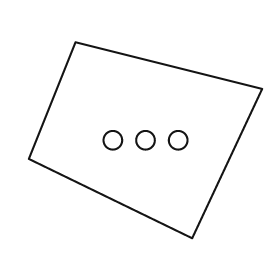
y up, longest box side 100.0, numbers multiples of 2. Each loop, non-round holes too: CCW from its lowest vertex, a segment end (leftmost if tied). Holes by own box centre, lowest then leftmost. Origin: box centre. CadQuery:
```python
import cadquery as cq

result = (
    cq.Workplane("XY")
    .moveTo(20.0, -42.0)
    .lineTo(50.0, 22.0)
    .lineTo(-30.0, 42.0)
    .lineTo(-50.0, -8.0)
    .close()
    .moveTo(-14.0, 0.0)
    .circle(4.0)
    .moveTo(0.0, 0.0)
    .circle(4.0)
    .moveTo(14.0, 0.0)
    .circle(4.0)
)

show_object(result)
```